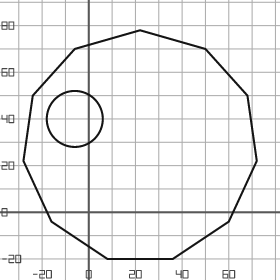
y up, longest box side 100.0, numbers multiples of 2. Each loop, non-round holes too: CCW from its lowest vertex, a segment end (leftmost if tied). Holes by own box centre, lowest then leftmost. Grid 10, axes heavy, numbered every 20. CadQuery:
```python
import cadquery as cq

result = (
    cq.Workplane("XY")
    .moveTo(8.0, -20.0)
    .lineTo(36.0, -20.0)
    .lineTo(60.0, -4.0)
    .lineTo(72.0, 22.0)
    .lineTo(68.0, 50.0)
    .lineTo(50.0, 70.0)
    .lineTo(22.0, 78.0)
    .lineTo(-6.0, 70.0)
    .lineTo(-24.0, 50.0)
    .lineTo(-28.0, 22.0)
    .lineTo(-16.0, -4.0)
    .close()
    .moveTo(-6.0, 40.0)
    .circle(12.0)
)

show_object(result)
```